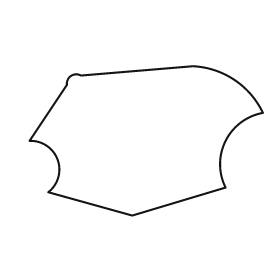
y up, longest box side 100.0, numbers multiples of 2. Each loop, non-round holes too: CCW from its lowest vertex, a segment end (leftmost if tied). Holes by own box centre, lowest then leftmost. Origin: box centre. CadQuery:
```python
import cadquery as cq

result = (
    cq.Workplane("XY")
    .moveTo(-6.0, -32.0)
    .lineTo(34.0, -20.0)
    .threePointArc((34.0, 0.0), (50.0, 12.0))
    .threePointArc((38.0, 26.0), (20.0, 32.0))
    .lineTo(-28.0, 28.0)
    .threePointArc((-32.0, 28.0), (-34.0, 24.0))
    .lineTo(-50.0, 0.0)
    .threePointArc((-38.0, -8.0), (-42.0, -22.0))
    .close()
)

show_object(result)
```